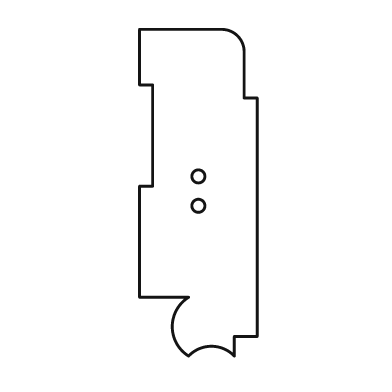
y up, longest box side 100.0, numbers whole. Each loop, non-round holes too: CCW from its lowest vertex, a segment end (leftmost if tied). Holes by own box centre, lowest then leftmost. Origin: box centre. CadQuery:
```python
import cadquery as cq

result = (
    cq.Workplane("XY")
    .moveTo(-3.0, -50.0)
    .threePointArc((4.0, -47.0), (11.0, -50.0))
    .lineTo(11.0, -44.0)
    .lineTo(18.0, -44.0)
    .lineTo(18.0, 29.0)
    .lineTo(14.0, 29.0)
    .lineTo(14.0, 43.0)
    .threePointArc((12.0, 48.0), (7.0, 50.0))
    .lineTo(-18.0, 50.0)
    .lineTo(-18.0, 33.0)
    .lineTo(-14.0, 33.0)
    .lineTo(-14.0, 2.0)
    .lineTo(-18.0, 2.0)
    .lineTo(-18.0, -32.0)
    .lineTo(-3.0, -32.0)
    .threePointArc((-8.0, -41.0), (-3.0, -50.0))
    .close()
    .moveTo(0.0, -4.0)
    .circle(2.0)
    .moveTo(0.0, 5.0)
    .circle(2.0)
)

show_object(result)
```